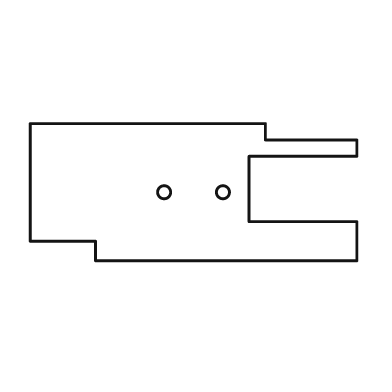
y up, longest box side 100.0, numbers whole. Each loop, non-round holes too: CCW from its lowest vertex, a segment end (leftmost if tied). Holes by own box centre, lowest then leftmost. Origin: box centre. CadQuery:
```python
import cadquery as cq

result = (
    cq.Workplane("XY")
    .moveTo(-30.0, -21.0)
    .lineTo(50.0, -21.0)
    .lineTo(50.0, -9.0)
    .lineTo(17.0, -9.0)
    .lineTo(17.0, 11.0)
    .lineTo(50.0, 11.0)
    .lineTo(50.0, 16.0)
    .lineTo(22.0, 16.0)
    .lineTo(22.0, 21.0)
    .lineTo(-50.0, 21.0)
    .lineTo(-50.0, -15.0)
    .lineTo(-30.0, -15.0)
    .close()
    .moveTo(-9.0, 0.0)
    .circle(2.0)
    .moveTo(9.0, 0.0)
    .circle(2.0)
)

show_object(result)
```